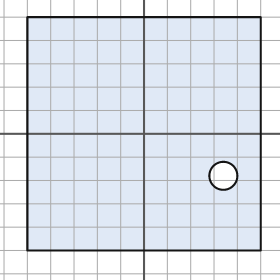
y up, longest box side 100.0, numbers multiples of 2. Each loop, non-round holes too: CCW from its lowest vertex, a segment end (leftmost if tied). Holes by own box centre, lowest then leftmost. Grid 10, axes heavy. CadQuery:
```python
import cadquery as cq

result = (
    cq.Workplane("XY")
    .moveTo(-50.0, -50.0)
    .lineTo(50.0, -50.0)
    .lineTo(50.0, 50.0)
    .lineTo(-50.0, 50.0)
    .close()
    .moveTo(34.0, -18.0)
    .circle(6.0)
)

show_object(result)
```